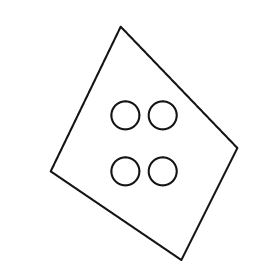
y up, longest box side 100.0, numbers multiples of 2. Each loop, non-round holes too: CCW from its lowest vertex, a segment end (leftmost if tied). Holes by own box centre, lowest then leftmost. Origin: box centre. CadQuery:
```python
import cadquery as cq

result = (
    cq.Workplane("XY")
    .moveTo(16.0, -50.0)
    .lineTo(40.0, -2.0)
    .lineTo(-10.0, 50.0)
    .lineTo(-40.0, -12.0)
    .close()
    .moveTo(-8.0, -12.0)
    .circle(6.0)
    .moveTo(8.0, -12.0)
    .circle(6.0)
    .moveTo(-8.0, 12.0)
    .circle(6.0)
    .moveTo(8.0, 12.0)
    .circle(6.0)
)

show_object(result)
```